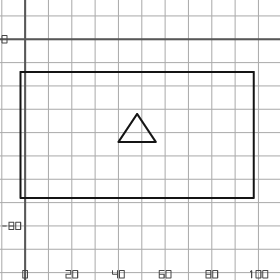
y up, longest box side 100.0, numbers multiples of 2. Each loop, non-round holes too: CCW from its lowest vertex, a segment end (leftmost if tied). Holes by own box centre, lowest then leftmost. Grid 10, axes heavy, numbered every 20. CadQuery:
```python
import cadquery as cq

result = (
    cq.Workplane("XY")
    .moveTo(-2.0, -68.0)
    .lineTo(98.0, -68.0)
    .lineTo(98.0, -14.0)
    .lineTo(-2.0, -14.0)
    .close()
    .moveTo(40.0, -44.0)
    .lineTo(56.0, -44.0)
    .lineTo(48.0, -32.0)
    .close()
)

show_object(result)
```